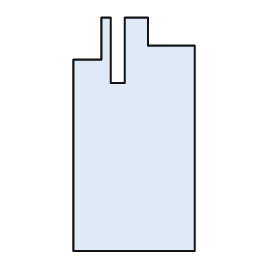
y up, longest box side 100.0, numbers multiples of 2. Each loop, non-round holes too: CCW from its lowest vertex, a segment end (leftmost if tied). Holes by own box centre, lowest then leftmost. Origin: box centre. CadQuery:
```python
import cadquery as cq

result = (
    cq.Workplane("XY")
    .moveTo(-26.0, -50.0)
    .lineTo(26.0, -50.0)
    .lineTo(26.0, 38.0)
    .lineTo(6.0, 38.0)
    .lineTo(6.0, 50.0)
    .lineTo(-4.0, 50.0)
    .lineTo(-4.0, 22.0)
    .lineTo(-10.0, 22.0)
    .lineTo(-10.0, 50.0)
    .lineTo(-14.0, 50.0)
    .lineTo(-14.0, 32.0)
    .lineTo(-26.0, 32.0)
    .close()
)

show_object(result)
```